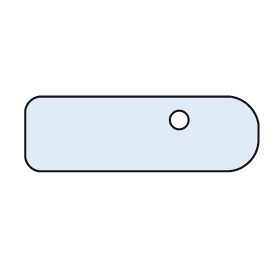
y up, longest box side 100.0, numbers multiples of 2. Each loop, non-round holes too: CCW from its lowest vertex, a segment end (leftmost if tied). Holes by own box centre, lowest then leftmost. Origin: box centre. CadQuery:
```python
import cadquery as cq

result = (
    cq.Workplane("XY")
    .moveTo(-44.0, -16.0)
    .lineTo(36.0, -16.0)
    .threePointArc((46.0, -12.0), (50.0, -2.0))
    .lineTo(50.0, 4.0)
    .threePointArc((46.0, 12.0), (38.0, 16.0))
    .lineTo(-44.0, 16.0)
    .threePointArc((-48.0, 14.0), (-50.0, 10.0))
    .lineTo(-50.0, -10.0)
    .threePointArc((-48.0, -14.0), (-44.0, -16.0))
    .close()
    .moveTo(16.0, 6.0)
    .circle(4.0)
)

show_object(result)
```